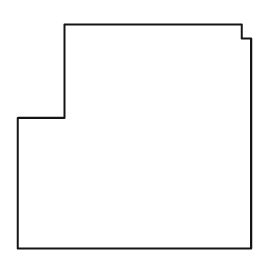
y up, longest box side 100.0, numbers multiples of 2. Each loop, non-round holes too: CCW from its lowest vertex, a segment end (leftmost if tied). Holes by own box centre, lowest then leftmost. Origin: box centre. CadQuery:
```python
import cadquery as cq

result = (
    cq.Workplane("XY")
    .moveTo(-50.0, -48.0)
    .lineTo(50.0, -48.0)
    .lineTo(50.0, 42.0)
    .lineTo(46.0, 42.0)
    .lineTo(46.0, 48.0)
    .lineTo(-30.0, 48.0)
    .lineTo(-30.0, 8.0)
    .lineTo(-50.0, 8.0)
    .close()
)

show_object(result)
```